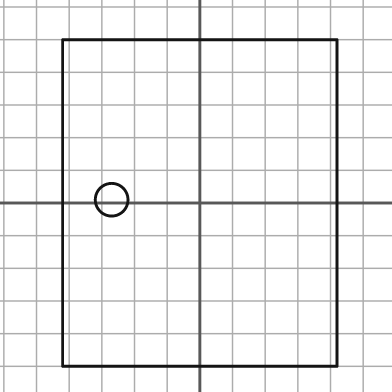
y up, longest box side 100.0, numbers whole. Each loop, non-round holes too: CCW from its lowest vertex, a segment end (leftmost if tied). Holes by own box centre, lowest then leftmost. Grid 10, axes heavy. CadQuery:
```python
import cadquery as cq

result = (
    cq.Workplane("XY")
    .moveTo(-42.0, -50.0)
    .lineTo(42.0, -50.0)
    .lineTo(42.0, 50.0)
    .lineTo(-42.0, 50.0)
    .close()
    .moveTo(-27.0, 1.0)
    .circle(5.0)
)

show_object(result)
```